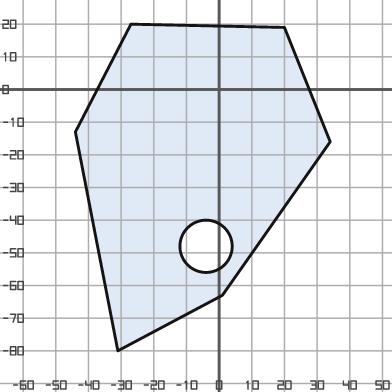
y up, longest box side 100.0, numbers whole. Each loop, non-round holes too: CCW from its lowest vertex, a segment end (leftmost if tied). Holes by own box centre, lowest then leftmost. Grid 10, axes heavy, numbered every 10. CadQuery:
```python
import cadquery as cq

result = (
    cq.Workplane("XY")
    .moveTo(-31.0, -80.0)
    .lineTo(1.0, -63.0)
    .lineTo(34.0, -16.0)
    .lineTo(20.0, 19.0)
    .lineTo(-27.0, 20.0)
    .lineTo(-44.0, -13.0)
    .close()
    .moveTo(-4.0, -48.0)
    .circle(8.0)
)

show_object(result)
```